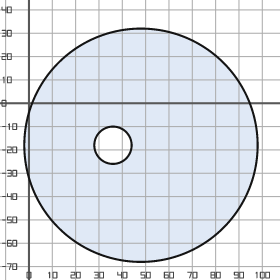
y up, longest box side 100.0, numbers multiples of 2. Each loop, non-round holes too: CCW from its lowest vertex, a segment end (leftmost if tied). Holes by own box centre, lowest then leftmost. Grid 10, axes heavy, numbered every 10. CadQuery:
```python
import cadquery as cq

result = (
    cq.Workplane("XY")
    .moveTo(48.0, -18.0)
    .circle(50.0)
    .moveTo(36.0, -18.0)
    .circle(8.0)
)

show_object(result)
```